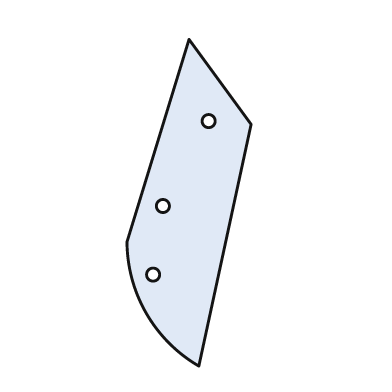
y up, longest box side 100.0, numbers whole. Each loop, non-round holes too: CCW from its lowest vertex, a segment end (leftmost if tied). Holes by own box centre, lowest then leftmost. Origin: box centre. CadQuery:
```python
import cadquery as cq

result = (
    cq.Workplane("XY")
    .moveTo(3.0, -50.0)
    .lineTo(19.0, 24.0)
    .lineTo(0.0, 50.0)
    .lineTo(-19.0, -12.0)
    .threePointArc((-13.0, -34.0), (3.0, -50.0))
    .close()
    .moveTo(-11.0, -22.0)
    .circle(2.0)
    .moveTo(-8.0, -1.0)
    .circle(2.0)
    .moveTo(6.0, 25.0)
    .circle(2.0)
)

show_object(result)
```